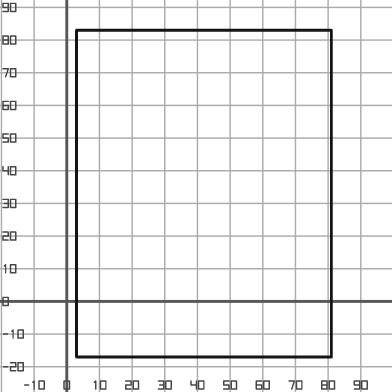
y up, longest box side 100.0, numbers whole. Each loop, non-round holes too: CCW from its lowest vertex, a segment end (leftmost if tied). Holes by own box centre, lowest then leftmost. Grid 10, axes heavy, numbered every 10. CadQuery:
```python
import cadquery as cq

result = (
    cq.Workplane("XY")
    .moveTo(3.0, -17.0)
    .lineTo(81.0, -17.0)
    .lineTo(81.0, 83.0)
    .lineTo(3.0, 83.0)
    .close()
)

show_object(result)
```